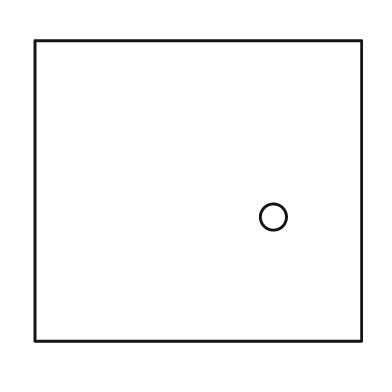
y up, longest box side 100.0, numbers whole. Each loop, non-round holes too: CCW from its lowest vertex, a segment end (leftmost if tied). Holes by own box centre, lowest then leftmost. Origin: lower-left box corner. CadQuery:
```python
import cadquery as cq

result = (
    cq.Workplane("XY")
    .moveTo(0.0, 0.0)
    .lineTo(100.0, 0.0)
    .lineTo(100.0, 92.0)
    .lineTo(0.0, 92.0)
    .close()
    .moveTo(73.0, 38.0)
    .circle(4.0)
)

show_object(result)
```